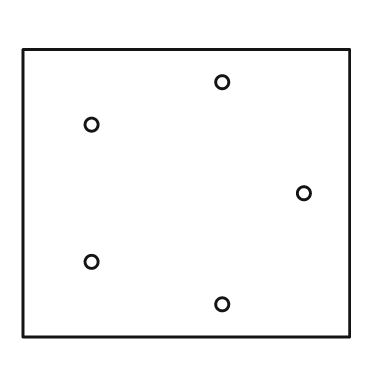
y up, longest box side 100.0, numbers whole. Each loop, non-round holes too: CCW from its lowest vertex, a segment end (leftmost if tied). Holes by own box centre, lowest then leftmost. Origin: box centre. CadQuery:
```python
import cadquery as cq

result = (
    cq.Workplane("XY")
    .moveTo(-50.0, -44.0)
    .lineTo(50.0, -44.0)
    .lineTo(50.0, 44.0)
    .lineTo(-50.0, 44.0)
    .close()
    .moveTo(11.0, -34.0)
    .circle(2.0)
    .moveTo(-29.0, -21.0)
    .circle(2.0)
    .moveTo(36.0, 0.0)
    .circle(2.0)
    .moveTo(-29.0, 21.0)
    .circle(2.0)
    .moveTo(11.0, 34.0)
    .circle(2.0)
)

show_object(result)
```